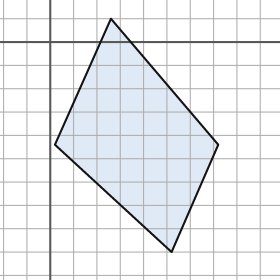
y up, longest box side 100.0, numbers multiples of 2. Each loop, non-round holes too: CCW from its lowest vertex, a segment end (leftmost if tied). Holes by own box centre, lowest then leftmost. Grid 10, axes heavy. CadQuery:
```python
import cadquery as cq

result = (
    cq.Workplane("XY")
    .moveTo(52.0, -90.0)
    .lineTo(72.0, -44.0)
    .lineTo(26.0, 10.0)
    .lineTo(2.0, -44.0)
    .close()
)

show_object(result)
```